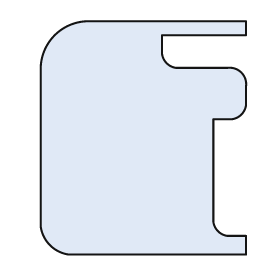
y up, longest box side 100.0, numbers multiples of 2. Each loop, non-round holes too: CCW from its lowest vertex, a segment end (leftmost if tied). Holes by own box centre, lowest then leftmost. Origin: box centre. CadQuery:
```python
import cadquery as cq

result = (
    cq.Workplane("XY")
    .moveTo(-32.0, -50.0)
    .lineTo(44.0, -50.0)
    .lineTo(44.0, -42.0)
    .lineTo(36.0, -42.0)
    .threePointArc((32.0, -40.0), (30.0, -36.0))
    .lineTo(30.0, 8.0)
    .lineTo(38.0, 8.0)
    .threePointArc((42.0, 10.0), (44.0, 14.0))
    .lineTo(44.0, 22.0)
    .threePointArc((42.0, 28.0), (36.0, 30.0))
    .lineTo(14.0, 30.0)
    .threePointArc((10.0, 32.0), (8.0, 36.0))
    .lineTo(8.0, 44.0)
    .lineTo(44.0, 44.0)
    .lineTo(44.0, 50.0)
    .lineTo(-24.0, 50.0)
    .threePointArc((-38.0, 44.0), (-44.0, 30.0))
    .lineTo(-44.0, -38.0)
    .threePointArc((-40.0, -46.0), (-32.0, -50.0))
    .close()
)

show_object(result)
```